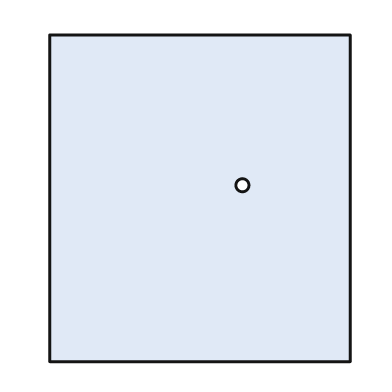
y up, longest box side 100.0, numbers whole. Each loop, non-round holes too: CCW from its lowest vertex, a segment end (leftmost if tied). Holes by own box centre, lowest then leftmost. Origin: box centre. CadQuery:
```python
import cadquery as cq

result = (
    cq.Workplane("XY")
    .moveTo(-46.0, -50.0)
    .lineTo(46.0, -50.0)
    .lineTo(46.0, 50.0)
    .lineTo(-46.0, 50.0)
    .close()
    .moveTo(13.0, 4.0)
    .circle(2.0)
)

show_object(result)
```